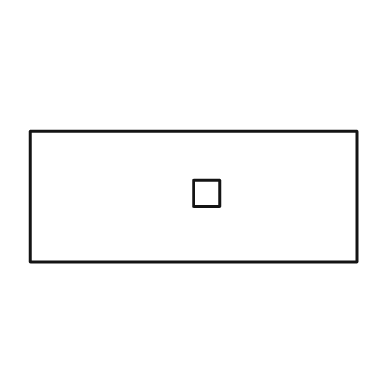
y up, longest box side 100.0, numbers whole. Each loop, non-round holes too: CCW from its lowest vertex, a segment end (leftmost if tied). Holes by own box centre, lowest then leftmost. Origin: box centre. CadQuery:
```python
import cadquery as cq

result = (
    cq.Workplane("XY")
    .moveTo(-50.0, -20.0)
    .lineTo(50.0, -20.0)
    .lineTo(50.0, 20.0)
    .lineTo(-50.0, 20.0)
    .close()
    .moveTo(0.0, -3.0)
    .lineTo(8.0, -3.0)
    .lineTo(8.0, 5.0)
    .lineTo(0.0, 5.0)
    .close()
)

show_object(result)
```